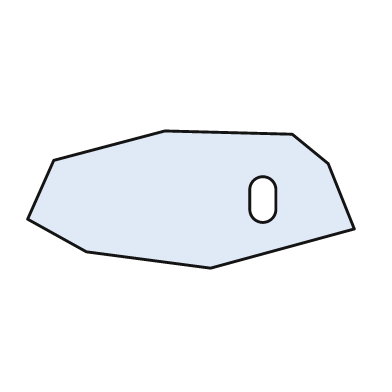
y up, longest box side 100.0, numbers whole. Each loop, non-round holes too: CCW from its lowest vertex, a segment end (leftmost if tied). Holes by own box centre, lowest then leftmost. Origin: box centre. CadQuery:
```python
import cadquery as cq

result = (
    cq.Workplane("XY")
    .moveTo(6.0, -21.0)
    .lineTo(50.0, -9.0)
    .lineTo(42.0, 11.0)
    .lineTo(31.0, 20.0)
    .lineTo(-8.0, 21.0)
    .lineTo(-42.0, 12.0)
    .lineTo(-50.0, -6.0)
    .lineTo(-32.0, -16.0)
    .close()
    .moveTo(18.0, -3.0)
    .threePointArc((22.0, -7.0), (26.0, -3.0))
    .lineTo(26.0, 3.0)
    .threePointArc((22.0, 7.0), (18.0, 3.0))
    .close()
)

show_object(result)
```